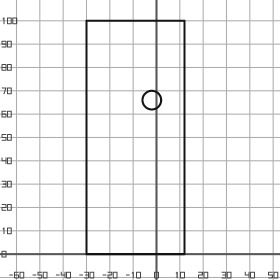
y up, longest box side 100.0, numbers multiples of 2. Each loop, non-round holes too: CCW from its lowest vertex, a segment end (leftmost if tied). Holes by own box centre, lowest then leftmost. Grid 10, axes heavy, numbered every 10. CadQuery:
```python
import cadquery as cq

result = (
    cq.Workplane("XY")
    .moveTo(-30.0, 0.0)
    .lineTo(12.0, 0.0)
    .lineTo(12.0, 100.0)
    .lineTo(-30.0, 100.0)
    .close()
    .moveTo(-2.0, 66.0)
    .circle(4.0)
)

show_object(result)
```